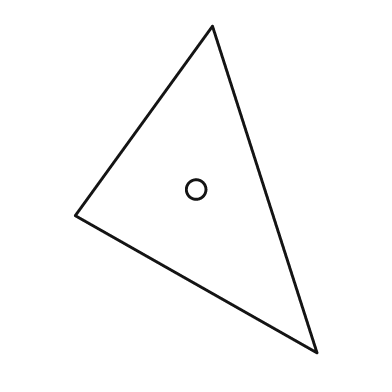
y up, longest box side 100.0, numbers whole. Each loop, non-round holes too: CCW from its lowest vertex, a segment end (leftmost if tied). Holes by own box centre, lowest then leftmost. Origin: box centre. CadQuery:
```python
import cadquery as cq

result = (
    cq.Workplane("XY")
    .moveTo(37.0, -50.0)
    .lineTo(5.0, 50.0)
    .lineTo(-37.0, -8.0)
    .close()
    .moveTo(0.0, 0.0)
    .circle(3.0)
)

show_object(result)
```